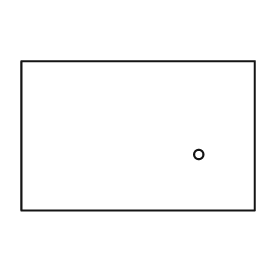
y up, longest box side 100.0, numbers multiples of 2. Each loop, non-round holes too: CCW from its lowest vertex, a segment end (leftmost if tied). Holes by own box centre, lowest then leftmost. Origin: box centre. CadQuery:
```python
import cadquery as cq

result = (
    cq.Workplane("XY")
    .moveTo(-50.0, -32.0)
    .lineTo(50.0, -32.0)
    .lineTo(50.0, 32.0)
    .lineTo(-50.0, 32.0)
    .close()
    .moveTo(26.0, -8.0)
    .circle(2.0)
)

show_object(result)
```